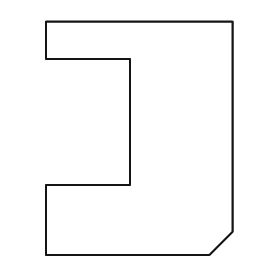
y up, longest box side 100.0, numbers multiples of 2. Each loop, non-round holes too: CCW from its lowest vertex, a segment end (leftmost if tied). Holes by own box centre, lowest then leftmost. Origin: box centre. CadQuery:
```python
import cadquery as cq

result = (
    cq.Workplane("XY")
    .moveTo(-40.0, -50.0)
    .lineTo(30.0, -50.0)
    .lineTo(40.0, -40.0)
    .lineTo(40.0, 50.0)
    .lineTo(-40.0, 50.0)
    .lineTo(-40.0, 34.0)
    .lineTo(-4.0, 34.0)
    .lineTo(-4.0, -20.0)
    .lineTo(-40.0, -20.0)
    .close()
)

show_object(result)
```